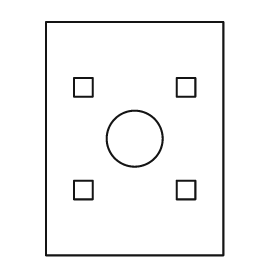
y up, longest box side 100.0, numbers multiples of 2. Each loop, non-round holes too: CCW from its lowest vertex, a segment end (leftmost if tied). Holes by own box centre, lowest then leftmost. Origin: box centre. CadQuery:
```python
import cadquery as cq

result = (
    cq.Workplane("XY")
    .moveTo(-38.0, -50.0)
    .lineTo(38.0, -50.0)
    .lineTo(38.0, 50.0)
    .lineTo(-38.0, 50.0)
    .close()
    .moveTo(-26.0, -26.0)
    .lineTo(-18.0, -26.0)
    .lineTo(-18.0, -18.0)
    .lineTo(-26.0, -18.0)
    .close()
    .moveTo(18.0, -26.0)
    .lineTo(26.0, -26.0)
    .lineTo(26.0, -18.0)
    .lineTo(18.0, -18.0)
    .close()
    .moveTo(0.0, 0.0)
    .circle(12.0)
    .moveTo(-26.0, 18.0)
    .lineTo(-18.0, 18.0)
    .lineTo(-18.0, 26.0)
    .lineTo(-26.0, 26.0)
    .close()
    .moveTo(18.0, 18.0)
    .lineTo(26.0, 18.0)
    .lineTo(26.0, 26.0)
    .lineTo(18.0, 26.0)
    .close()
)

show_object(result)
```